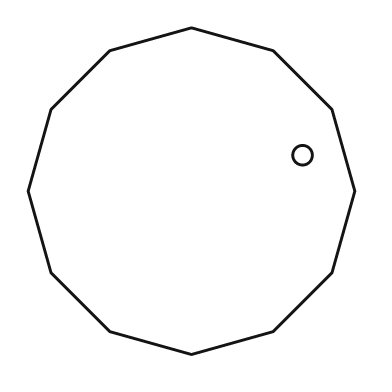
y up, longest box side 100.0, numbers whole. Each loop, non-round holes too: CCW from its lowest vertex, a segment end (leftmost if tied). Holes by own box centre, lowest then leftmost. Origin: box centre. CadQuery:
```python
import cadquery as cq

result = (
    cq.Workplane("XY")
    .moveTo(0.0, -50.0)
    .lineTo(25.0, -43.0)
    .lineTo(43.0, -25.0)
    .lineTo(50.0, 0.0)
    .lineTo(43.0, 25.0)
    .lineTo(25.0, 43.0)
    .lineTo(0.0, 50.0)
    .lineTo(-25.0, 43.0)
    .lineTo(-43.0, 25.0)
    .lineTo(-50.0, 0.0)
    .lineTo(-43.0, -25.0)
    .lineTo(-25.0, -43.0)
    .close()
    .moveTo(34.0, 11.0)
    .circle(3.0)
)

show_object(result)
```